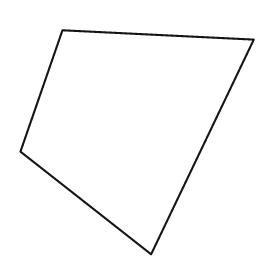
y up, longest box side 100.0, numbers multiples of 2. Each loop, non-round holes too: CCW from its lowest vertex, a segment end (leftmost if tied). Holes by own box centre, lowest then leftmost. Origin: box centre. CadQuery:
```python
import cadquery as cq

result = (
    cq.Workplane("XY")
    .moveTo(6.0, -48.0)
    .lineTo(50.0, 44.0)
    .lineTo(-32.0, 48.0)
    .lineTo(-50.0, -4.0)
    .close()
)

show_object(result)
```